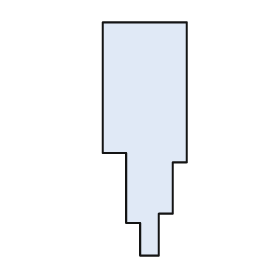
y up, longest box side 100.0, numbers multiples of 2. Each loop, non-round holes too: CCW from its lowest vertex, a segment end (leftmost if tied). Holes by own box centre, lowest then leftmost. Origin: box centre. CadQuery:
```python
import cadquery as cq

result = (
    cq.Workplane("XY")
    .moveTo(-2.0, -50.0)
    .lineTo(6.0, -50.0)
    .lineTo(6.0, -32.0)
    .lineTo(12.0, -32.0)
    .lineTo(12.0, -10.0)
    .lineTo(18.0, -10.0)
    .lineTo(18.0, 50.0)
    .lineTo(-18.0, 50.0)
    .lineTo(-18.0, -6.0)
    .lineTo(-8.0, -6.0)
    .lineTo(-8.0, -36.0)
    .lineTo(-2.0, -36.0)
    .close()
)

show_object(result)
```